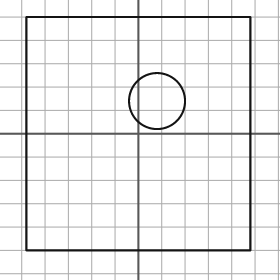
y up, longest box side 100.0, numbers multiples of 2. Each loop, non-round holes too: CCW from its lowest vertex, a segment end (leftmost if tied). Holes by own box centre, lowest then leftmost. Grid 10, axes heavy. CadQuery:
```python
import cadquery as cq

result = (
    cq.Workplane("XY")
    .moveTo(-48.0, -50.0)
    .lineTo(48.0, -50.0)
    .lineTo(48.0, 50.0)
    .lineTo(-48.0, 50.0)
    .close()
    .moveTo(8.0, 14.0)
    .circle(12.0)
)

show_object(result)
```